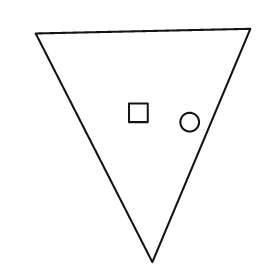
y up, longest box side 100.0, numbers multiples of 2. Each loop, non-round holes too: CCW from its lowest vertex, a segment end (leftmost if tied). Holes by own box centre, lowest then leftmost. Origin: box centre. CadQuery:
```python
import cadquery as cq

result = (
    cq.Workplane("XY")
    .moveTo(4.0, -50.0)
    .lineTo(46.0, 50.0)
    .lineTo(-46.0, 48.0)
    .close()
    .moveTo(20.0, 10.0)
    .circle(4.0)
    .moveTo(-6.0, 10.0)
    .lineTo(2.0, 10.0)
    .lineTo(2.0, 18.0)
    .lineTo(-6.0, 18.0)
    .close()
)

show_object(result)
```